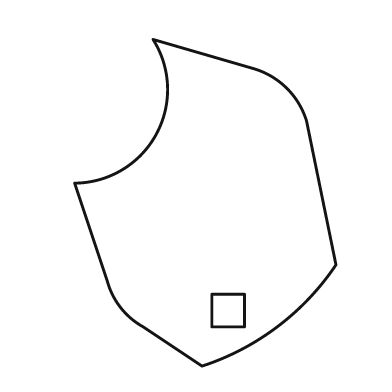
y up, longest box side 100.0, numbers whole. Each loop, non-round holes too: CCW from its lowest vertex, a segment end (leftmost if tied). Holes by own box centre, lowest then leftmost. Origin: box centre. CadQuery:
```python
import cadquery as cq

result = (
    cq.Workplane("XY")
    .moveTo(-1.0, -50.0)
    .threePointArc((22.0, -38.0), (40.0, -19.0))
    .lineTo(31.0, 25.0)
    .threePointArc((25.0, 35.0), (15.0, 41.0))
    .lineTo(-16.0, 50.0)
    .threePointArc((-15.0, 21.0), (-40.0, 6.0))
    .lineTo(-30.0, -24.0)
    .threePointArc((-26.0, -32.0), (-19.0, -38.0))
    .close()
    .moveTo(2.0, -38.0)
    .lineTo(12.0, -38.0)
    .lineTo(12.0, -28.0)
    .lineTo(2.0, -28.0)
    .close()
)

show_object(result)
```